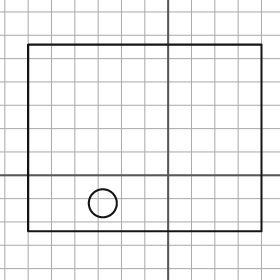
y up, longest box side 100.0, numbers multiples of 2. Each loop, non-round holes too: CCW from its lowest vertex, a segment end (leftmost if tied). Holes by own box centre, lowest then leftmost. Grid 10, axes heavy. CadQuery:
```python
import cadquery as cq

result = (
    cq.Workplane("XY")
    .moveTo(-60.0, -24.0)
    .lineTo(40.0, -24.0)
    .lineTo(40.0, 56.0)
    .lineTo(-60.0, 56.0)
    .close()
    .moveTo(-28.0, -12.0)
    .circle(6.0)
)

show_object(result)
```